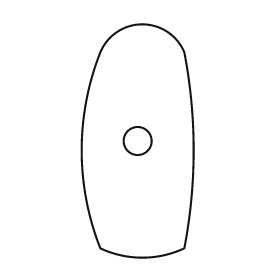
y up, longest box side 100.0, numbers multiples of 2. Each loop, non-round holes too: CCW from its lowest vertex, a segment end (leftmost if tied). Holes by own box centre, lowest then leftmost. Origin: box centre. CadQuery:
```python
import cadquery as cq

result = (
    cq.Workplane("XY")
    .moveTo(-16.0, -46.0)
    .threePointArc((2.0, -50.0), (20.0, -46.0))
    .threePointArc((24.0, -4.0), (20.0, 38.0))
    .threePointArc((2.0, 50.0), (-16.0, 38.0))
    .threePointArc((-24.0, -4.0), (-16.0, -46.0))
    .close()
    .moveTo(0.0, 0.0)
    .circle(6.0)
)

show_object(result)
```